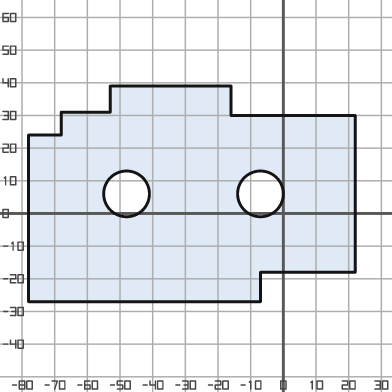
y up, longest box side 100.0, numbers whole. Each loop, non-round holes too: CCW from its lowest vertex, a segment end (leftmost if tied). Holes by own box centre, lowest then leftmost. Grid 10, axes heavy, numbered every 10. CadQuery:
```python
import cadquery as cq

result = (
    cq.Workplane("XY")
    .moveTo(-78.0, -27.0)
    .lineTo(-7.0, -27.0)
    .lineTo(-7.0, -18.0)
    .lineTo(22.0, -18.0)
    .lineTo(22.0, 30.0)
    .lineTo(-16.0, 30.0)
    .lineTo(-16.0, 39.0)
    .lineTo(-53.0, 39.0)
    .lineTo(-53.0, 31.0)
    .lineTo(-68.0, 31.0)
    .lineTo(-68.0, 24.0)
    .lineTo(-78.0, 24.0)
    .close()
    .moveTo(-48.0, 6.0)
    .circle(7.0)
    .moveTo(-7.0, 6.0)
    .circle(7.0)
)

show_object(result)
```